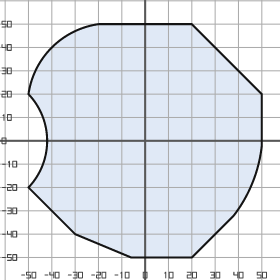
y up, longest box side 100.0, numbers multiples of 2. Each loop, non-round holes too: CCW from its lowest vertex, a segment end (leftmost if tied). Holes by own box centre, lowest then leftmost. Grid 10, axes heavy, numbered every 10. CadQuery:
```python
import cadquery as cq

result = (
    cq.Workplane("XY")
    .moveTo(-6.0, -50.0)
    .lineTo(20.0, -50.0)
    .lineTo(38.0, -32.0)
    .threePointArc((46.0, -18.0), (50.0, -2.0))
    .lineTo(50.0, 20.0)
    .lineTo(20.0, 50.0)
    .lineTo(-20.0, 50.0)
    .threePointArc((-40.0, 40.0), (-50.0, 20.0))
    .threePointArc((-42.0, 0.0), (-50.0, -20.0))
    .lineTo(-30.0, -40.0)
    .close()
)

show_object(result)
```